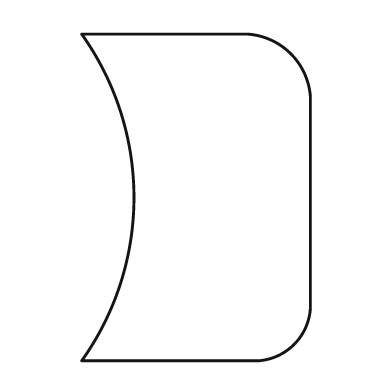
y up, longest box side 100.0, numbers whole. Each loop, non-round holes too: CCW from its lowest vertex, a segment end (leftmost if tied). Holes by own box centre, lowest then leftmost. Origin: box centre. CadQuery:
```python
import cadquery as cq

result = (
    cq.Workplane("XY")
    .moveTo(-35.0, -50.0)
    .lineTo(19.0, -50.0)
    .threePointArc((30.0, -45.0), (35.0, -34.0))
    .lineTo(35.0, 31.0)
    .threePointArc((29.0, 44.0), (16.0, 50.0))
    .lineTo(-35.0, 50.0)
    .threePointArc((-19.0, 0.0), (-35.0, -50.0))
    .close()
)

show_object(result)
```